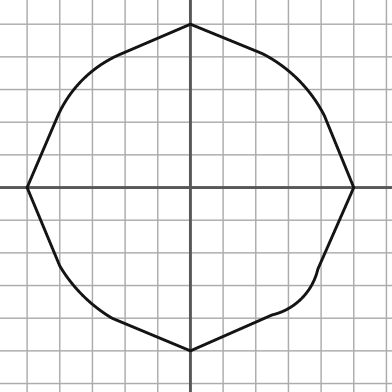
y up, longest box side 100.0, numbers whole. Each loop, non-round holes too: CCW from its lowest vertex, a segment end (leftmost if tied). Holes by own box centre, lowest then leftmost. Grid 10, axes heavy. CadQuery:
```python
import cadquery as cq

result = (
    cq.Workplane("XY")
    .moveTo(0.0, -50.0)
    .lineTo(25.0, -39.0)
    .threePointArc((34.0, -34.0), (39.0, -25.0))
    .lineTo(50.0, 0.0)
    .lineTo(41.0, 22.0)
    .threePointArc((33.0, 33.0), (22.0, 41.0))
    .lineTo(0.0, 50.0)
    .lineTo(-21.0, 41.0)
    .threePointArc((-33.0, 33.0), (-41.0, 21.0))
    .lineTo(-50.0, 0.0)
    .lineTo(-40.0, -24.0)
    .threePointArc((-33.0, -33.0), (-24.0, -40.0))
    .close()
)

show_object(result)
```